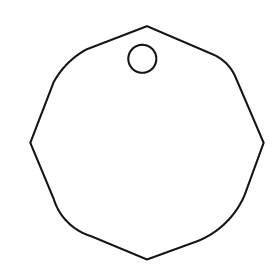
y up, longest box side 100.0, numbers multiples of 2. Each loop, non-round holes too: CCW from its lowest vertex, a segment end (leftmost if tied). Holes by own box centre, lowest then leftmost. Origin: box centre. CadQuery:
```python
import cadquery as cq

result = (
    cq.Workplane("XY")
    .moveTo(0.0, -50.0)
    .lineTo(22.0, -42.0)
    .threePointArc((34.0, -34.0), (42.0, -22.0))
    .lineTo(50.0, 0.0)
    .lineTo(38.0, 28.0)
    .threePointArc((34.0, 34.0), (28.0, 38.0))
    .lineTo(0.0, 50.0)
    .lineTo(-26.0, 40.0)
    .threePointArc((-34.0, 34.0), (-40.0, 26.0))
    .lineTo(-50.0, 0.0)
    .lineTo(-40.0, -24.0)
    .threePointArc((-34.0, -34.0), (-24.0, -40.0))
    .close()
    .moveTo(-2.0, 36.0)
    .circle(6.0)
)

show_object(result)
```